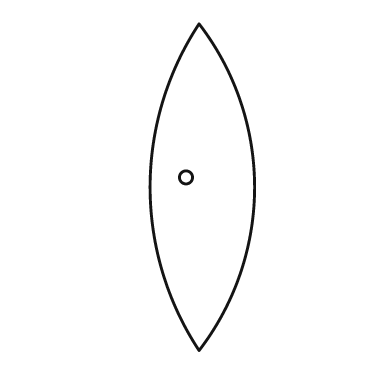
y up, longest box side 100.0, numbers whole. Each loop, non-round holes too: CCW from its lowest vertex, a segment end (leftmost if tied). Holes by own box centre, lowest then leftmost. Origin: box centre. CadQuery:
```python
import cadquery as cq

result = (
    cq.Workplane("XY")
    .moveTo(-1.0, -50.0)
    .threePointArc((16.0, 0.0), (-1.0, 50.0))
    .threePointArc((-16.0, 0.0), (-1.0, -50.0))
    .close()
    .moveTo(-5.0, 3.0)
    .circle(2.0)
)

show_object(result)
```